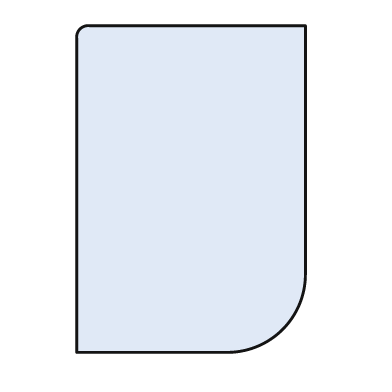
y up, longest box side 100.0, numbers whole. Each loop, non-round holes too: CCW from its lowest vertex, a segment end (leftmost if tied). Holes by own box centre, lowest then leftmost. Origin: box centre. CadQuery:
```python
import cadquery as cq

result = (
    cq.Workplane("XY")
    .moveTo(-35.0, -50.0)
    .lineTo(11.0, -50.0)
    .threePointArc((28.0, -43.0), (35.0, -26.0))
    .lineTo(35.0, 50.0)
    .lineTo(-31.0, 50.0)
    .threePointArc((-34.0, 49.0), (-35.0, 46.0))
    .close()
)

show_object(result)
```